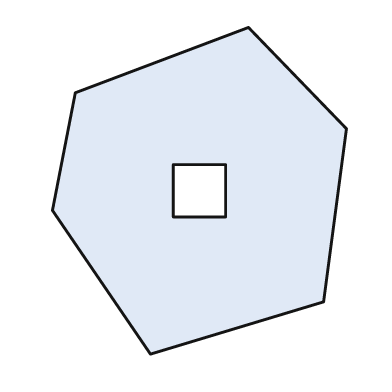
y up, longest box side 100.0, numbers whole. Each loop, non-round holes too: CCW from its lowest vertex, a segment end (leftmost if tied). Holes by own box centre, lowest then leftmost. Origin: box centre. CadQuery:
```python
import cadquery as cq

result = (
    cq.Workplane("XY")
    .moveTo(-15.0, -50.0)
    .lineTo(38.0, -34.0)
    .lineTo(45.0, 19.0)
    .lineTo(15.0, 50.0)
    .lineTo(-38.0, 30.0)
    .lineTo(-45.0, -6.0)
    .close()
    .moveTo(-8.0, -8.0)
    .lineTo(8.0, -8.0)
    .lineTo(8.0, 8.0)
    .lineTo(-8.0, 8.0)
    .close()
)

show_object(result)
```